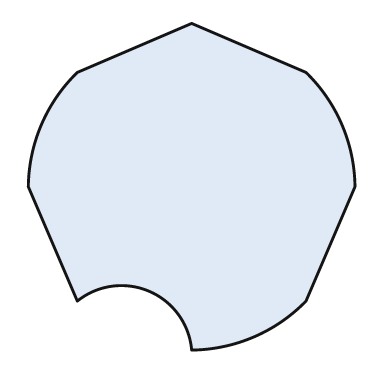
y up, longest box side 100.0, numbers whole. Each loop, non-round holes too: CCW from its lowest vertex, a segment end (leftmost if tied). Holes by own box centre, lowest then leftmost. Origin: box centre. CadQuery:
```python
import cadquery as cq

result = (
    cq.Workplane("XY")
    .moveTo(0.0, -50.0)
    .threePointArc((19.0, -46.0), (35.0, -35.0))
    .lineTo(50.0, 0.0)
    .threePointArc((46.0, 19.0), (35.0, 35.0))
    .lineTo(0.0, 50.0)
    .lineTo(-35.0, 35.0)
    .threePointArc((-46.0, 19.0), (-50.0, 0.0))
    .lineTo(-35.0, -35.0)
    .threePointArc((-13.0, -32.0), (0.0, -50.0))
    .close()
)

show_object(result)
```